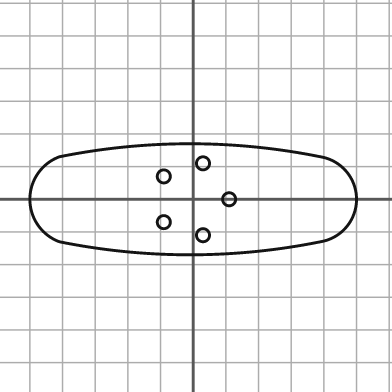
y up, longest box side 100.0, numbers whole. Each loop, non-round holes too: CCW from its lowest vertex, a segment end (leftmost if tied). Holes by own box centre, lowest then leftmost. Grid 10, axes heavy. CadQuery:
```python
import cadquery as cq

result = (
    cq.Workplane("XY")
    .moveTo(-41.0, -13.0)
    .threePointArc((-1.0, -17.0), (39.0, -13.0))
    .threePointArc((50.0, 0.0), (39.0, 13.0))
    .threePointArc((-1.0, 17.0), (-41.0, 13.0))
    .threePointArc((-50.0, 0.0), (-41.0, -13.0))
    .close()
    .moveTo(3.0, -11.0)
    .circle(2.0)
    .moveTo(-9.0, -7.0)
    .circle(2.0)
    .moveTo(11.0, 0.0)
    .circle(2.0)
    .moveTo(-9.0, 7.0)
    .circle(2.0)
    .moveTo(3.0, 11.0)
    .circle(2.0)
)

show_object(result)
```